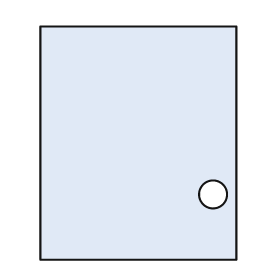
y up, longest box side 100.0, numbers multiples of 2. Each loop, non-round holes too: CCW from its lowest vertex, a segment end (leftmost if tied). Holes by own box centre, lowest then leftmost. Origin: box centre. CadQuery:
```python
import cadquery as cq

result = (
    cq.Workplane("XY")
    .moveTo(-42.0, -50.0)
    .lineTo(42.0, -50.0)
    .lineTo(42.0, 50.0)
    .lineTo(-42.0, 50.0)
    .close()
    .moveTo(32.0, -22.0)
    .circle(6.0)
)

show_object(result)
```